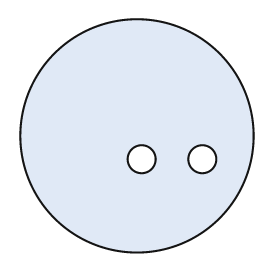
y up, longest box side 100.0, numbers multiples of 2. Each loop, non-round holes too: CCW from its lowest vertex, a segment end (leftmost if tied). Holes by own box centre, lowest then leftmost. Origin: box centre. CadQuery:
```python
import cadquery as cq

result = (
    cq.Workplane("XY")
    .moveTo(0.0, 0.0)
    .circle(50.0)
    .moveTo(2.0, -10.0)
    .circle(6.0)
    .moveTo(28.0, -10.0)
    .circle(6.0)
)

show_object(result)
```